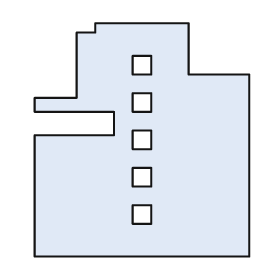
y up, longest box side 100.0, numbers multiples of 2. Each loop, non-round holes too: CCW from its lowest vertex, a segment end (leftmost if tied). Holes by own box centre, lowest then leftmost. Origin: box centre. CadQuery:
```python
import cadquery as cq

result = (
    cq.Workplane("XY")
    .moveTo(-46.0, -50.0)
    .lineTo(46.0, -50.0)
    .lineTo(46.0, 28.0)
    .lineTo(20.0, 28.0)
    .lineTo(20.0, 50.0)
    .lineTo(-20.0, 50.0)
    .lineTo(-20.0, 46.0)
    .lineTo(-28.0, 46.0)
    .lineTo(-28.0, 18.0)
    .lineTo(-46.0, 18.0)
    .lineTo(-46.0, 12.0)
    .lineTo(-12.0, 12.0)
    .lineTo(-12.0, 2.0)
    .lineTo(-46.0, 2.0)
    .close()
    .moveTo(-4.0, -36.0)
    .lineTo(4.0, -36.0)
    .lineTo(4.0, -28.0)
    .lineTo(-4.0, -28.0)
    .close()
    .moveTo(-4.0, -20.0)
    .lineTo(4.0, -20.0)
    .lineTo(4.0, -12.0)
    .lineTo(-4.0, -12.0)
    .close()
    .moveTo(-4.0, -4.0)
    .lineTo(4.0, -4.0)
    .lineTo(4.0, 4.0)
    .lineTo(-4.0, 4.0)
    .close()
    .moveTo(-4.0, 12.0)
    .lineTo(4.0, 12.0)
    .lineTo(4.0, 20.0)
    .lineTo(-4.0, 20.0)
    .close()
    .moveTo(-4.0, 28.0)
    .lineTo(4.0, 28.0)
    .lineTo(4.0, 36.0)
    .lineTo(-4.0, 36.0)
    .close()
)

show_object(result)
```